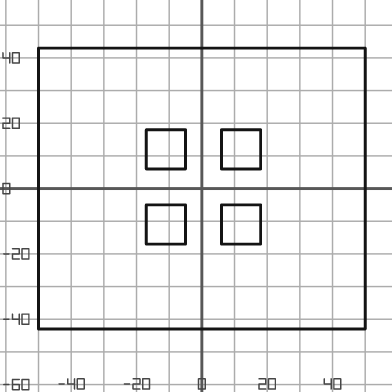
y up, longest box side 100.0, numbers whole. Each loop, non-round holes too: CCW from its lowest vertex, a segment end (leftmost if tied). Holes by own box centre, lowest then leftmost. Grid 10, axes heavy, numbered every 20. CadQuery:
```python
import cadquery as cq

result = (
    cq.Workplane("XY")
    .moveTo(-50.0, -43.0)
    .lineTo(50.0, -43.0)
    .lineTo(50.0, 43.0)
    .lineTo(-50.0, 43.0)
    .close()
    .moveTo(-17.0, -17.0)
    .lineTo(-5.0, -17.0)
    .lineTo(-5.0, -5.0)
    .lineTo(-17.0, -5.0)
    .close()
    .moveTo(6.0, -17.0)
    .lineTo(18.0, -17.0)
    .lineTo(18.0, -5.0)
    .lineTo(6.0, -5.0)
    .close()
    .moveTo(-17.0, 6.0)
    .lineTo(-5.0, 6.0)
    .lineTo(-5.0, 18.0)
    .lineTo(-17.0, 18.0)
    .close()
    .moveTo(6.0, 6.0)
    .lineTo(18.0, 6.0)
    .lineTo(18.0, 18.0)
    .lineTo(6.0, 18.0)
    .close()
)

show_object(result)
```